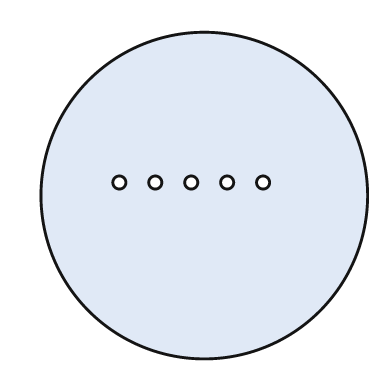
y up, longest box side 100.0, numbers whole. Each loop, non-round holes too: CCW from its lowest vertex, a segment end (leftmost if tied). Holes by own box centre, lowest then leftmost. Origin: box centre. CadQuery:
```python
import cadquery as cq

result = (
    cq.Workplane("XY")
    .moveTo(0.0, 0.0)
    .circle(50.0)
    .moveTo(-26.0, 4.0)
    .circle(2.0)
    .moveTo(-15.0, 4.0)
    .circle(2.0)
    .moveTo(-4.0, 4.0)
    .circle(2.0)
    .moveTo(7.0, 4.0)
    .circle(2.0)
    .moveTo(18.0, 4.0)
    .circle(2.0)
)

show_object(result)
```